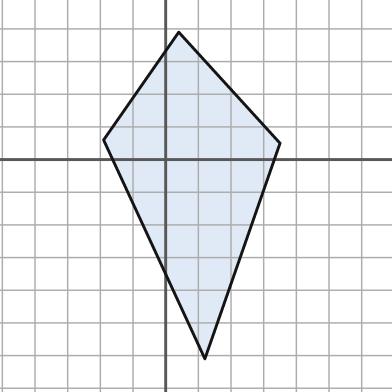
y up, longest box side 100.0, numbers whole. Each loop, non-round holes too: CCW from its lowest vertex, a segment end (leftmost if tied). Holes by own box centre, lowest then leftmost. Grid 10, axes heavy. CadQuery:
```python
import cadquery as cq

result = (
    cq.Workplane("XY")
    .moveTo(12.0, -61.0)
    .lineTo(35.0, 5.0)
    .lineTo(4.0, 39.0)
    .lineTo(-19.0, 6.0)
    .close()
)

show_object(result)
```